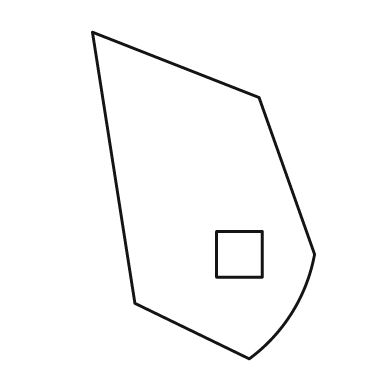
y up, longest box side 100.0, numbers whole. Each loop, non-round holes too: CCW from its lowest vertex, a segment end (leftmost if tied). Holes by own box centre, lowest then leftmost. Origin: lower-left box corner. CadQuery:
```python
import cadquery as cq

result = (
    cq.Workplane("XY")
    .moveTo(48.0, 0.0)
    .threePointArc((61.0, 14.0), (68.0, 32.0))
    .lineTo(51.0, 80.0)
    .lineTo(0.0, 100.0)
    .lineTo(13.0, 17.0)
    .close()
    .moveTo(38.0, 25.0)
    .lineTo(52.0, 25.0)
    .lineTo(52.0, 39.0)
    .lineTo(38.0, 39.0)
    .close()
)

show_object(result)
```